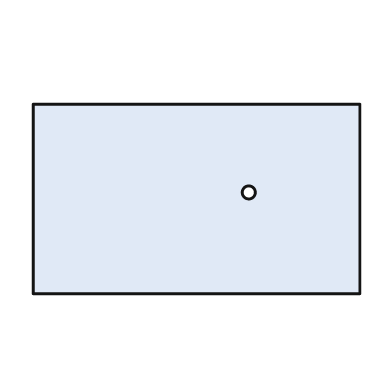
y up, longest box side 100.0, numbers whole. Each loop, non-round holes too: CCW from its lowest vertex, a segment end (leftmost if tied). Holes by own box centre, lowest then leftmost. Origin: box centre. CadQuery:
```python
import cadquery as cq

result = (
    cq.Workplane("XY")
    .moveTo(-50.0, -29.0)
    .lineTo(50.0, -29.0)
    .lineTo(50.0, 29.0)
    .lineTo(-50.0, 29.0)
    .close()
    .moveTo(16.0, 2.0)
    .circle(2.0)
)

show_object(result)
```